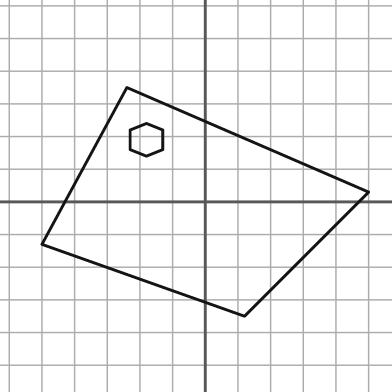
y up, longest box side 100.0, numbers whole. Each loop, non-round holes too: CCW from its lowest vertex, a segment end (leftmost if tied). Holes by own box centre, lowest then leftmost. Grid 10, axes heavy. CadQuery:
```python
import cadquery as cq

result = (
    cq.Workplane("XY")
    .moveTo(12.0, -35.0)
    .lineTo(50.0, 3.0)
    .lineTo(-24.0, 35.0)
    .lineTo(-50.0, -13.0)
    .close()
    .moveTo(-18.0, 14.0)
    .lineTo(-13.0, 16.0)
    .lineTo(-13.0, 22.0)
    .lineTo(-18.0, 24.0)
    .lineTo(-23.0, 22.0)
    .lineTo(-23.0, 16.0)
    .close()
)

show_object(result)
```